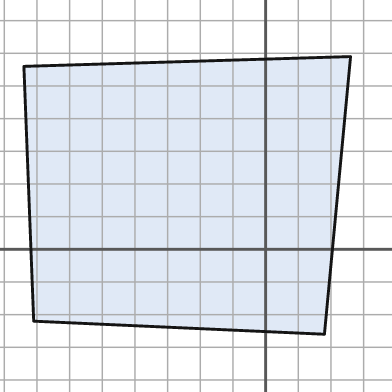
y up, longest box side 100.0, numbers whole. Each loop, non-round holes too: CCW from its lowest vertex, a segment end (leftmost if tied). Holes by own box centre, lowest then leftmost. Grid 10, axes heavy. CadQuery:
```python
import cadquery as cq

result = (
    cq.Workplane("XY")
    .moveTo(18.0, -26.0)
    .lineTo(26.0, 59.0)
    .lineTo(-74.0, 56.0)
    .lineTo(-71.0, -22.0)
    .close()
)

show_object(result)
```